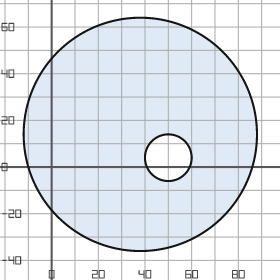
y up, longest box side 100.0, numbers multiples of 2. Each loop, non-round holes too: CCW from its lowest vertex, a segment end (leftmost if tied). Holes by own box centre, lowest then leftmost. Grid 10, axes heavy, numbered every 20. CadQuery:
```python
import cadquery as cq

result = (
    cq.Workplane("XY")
    .moveTo(38.0, 14.0)
    .circle(50.0)
    .moveTo(50.0, 4.0)
    .circle(10.0)
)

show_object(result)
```